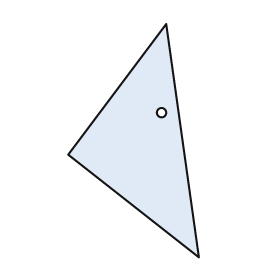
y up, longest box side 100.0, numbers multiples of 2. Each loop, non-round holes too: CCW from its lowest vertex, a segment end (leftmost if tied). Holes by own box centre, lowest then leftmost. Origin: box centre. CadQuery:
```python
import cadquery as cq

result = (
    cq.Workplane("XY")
    .moveTo(28.0, -50.0)
    .lineTo(14.0, 50.0)
    .lineTo(-28.0, -6.0)
    .close()
    .moveTo(12.0, 12.0)
    .circle(2.0)
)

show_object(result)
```